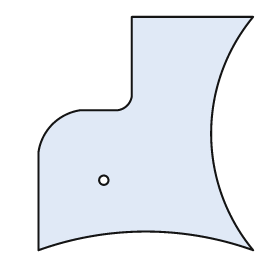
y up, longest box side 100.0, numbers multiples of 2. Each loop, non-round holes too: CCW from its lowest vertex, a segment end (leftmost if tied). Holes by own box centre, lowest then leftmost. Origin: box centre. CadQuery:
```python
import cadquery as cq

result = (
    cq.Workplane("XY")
    .moveTo(-46.0, -50.0)
    .threePointArc((0.0, -42.0), (46.0, -50.0))
    .threePointArc((28.0, 0.0), (46.0, 50.0))
    .lineTo(-6.0, 50.0)
    .lineTo(-6.0, 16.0)
    .threePointArc((-8.0, 12.0), (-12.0, 10.0))
    .lineTo(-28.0, 10.0)
    .threePointArc((-40.0, 4.0), (-46.0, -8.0))
    .close()
    .moveTo(-18.0, -20.0)
    .circle(2.0)
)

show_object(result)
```